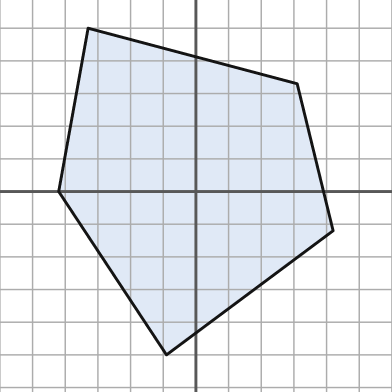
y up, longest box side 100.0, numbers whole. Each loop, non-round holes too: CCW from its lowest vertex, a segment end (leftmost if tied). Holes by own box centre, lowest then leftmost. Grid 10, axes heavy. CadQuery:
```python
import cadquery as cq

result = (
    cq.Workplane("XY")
    .moveTo(-9.0, -50.0)
    .lineTo(42.0, -12.0)
    .lineTo(31.0, 33.0)
    .lineTo(-33.0, 50.0)
    .lineTo(-42.0, 0.0)
    .close()
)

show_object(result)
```